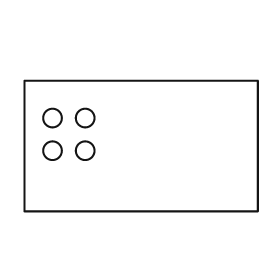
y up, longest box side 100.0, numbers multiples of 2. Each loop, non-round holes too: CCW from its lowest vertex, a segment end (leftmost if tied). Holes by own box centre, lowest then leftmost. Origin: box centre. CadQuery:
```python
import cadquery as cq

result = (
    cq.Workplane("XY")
    .moveTo(-50.0, -28.0)
    .lineTo(50.0, -28.0)
    .lineTo(50.0, 28.0)
    .lineTo(-50.0, 28.0)
    .close()
    .moveTo(-38.0, -2.0)
    .circle(4.0)
    .moveTo(-24.0, -2.0)
    .circle(4.0)
    .moveTo(-38.0, 12.0)
    .circle(4.0)
    .moveTo(-24.0, 12.0)
    .circle(4.0)
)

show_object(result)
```